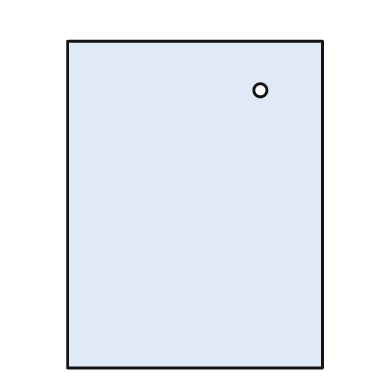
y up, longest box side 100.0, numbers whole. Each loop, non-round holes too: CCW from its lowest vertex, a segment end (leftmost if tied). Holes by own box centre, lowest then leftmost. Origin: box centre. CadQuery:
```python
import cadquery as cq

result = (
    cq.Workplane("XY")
    .moveTo(-39.0, -50.0)
    .lineTo(39.0, -50.0)
    .lineTo(39.0, 50.0)
    .lineTo(-39.0, 50.0)
    .close()
    .moveTo(20.0, 35.0)
    .circle(2.0)
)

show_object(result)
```